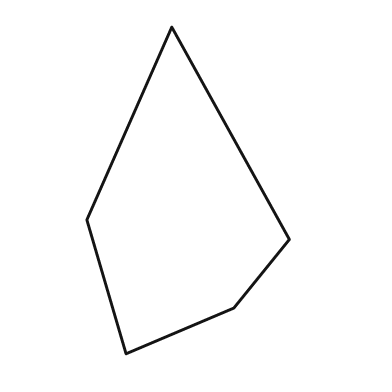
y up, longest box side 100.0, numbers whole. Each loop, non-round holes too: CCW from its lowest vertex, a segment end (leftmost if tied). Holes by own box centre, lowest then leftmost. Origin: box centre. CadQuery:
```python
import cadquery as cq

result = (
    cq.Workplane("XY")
    .moveTo(-19.0, -50.0)
    .lineTo(14.0, -36.0)
    .lineTo(31.0, -15.0)
    .lineTo(-5.0, 50.0)
    .lineTo(-31.0, -9.0)
    .close()
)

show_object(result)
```